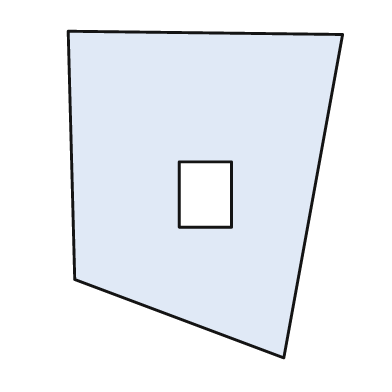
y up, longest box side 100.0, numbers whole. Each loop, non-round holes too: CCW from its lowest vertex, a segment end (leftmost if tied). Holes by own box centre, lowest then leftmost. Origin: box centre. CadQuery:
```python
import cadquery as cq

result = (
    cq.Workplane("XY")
    .moveTo(24.0, -50.0)
    .lineTo(42.0, 49.0)
    .lineTo(-42.0, 50.0)
    .lineTo(-40.0, -26.0)
    .close()
    .moveTo(-8.0, -10.0)
    .lineTo(8.0, -10.0)
    .lineTo(8.0, 10.0)
    .lineTo(-8.0, 10.0)
    .close()
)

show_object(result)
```